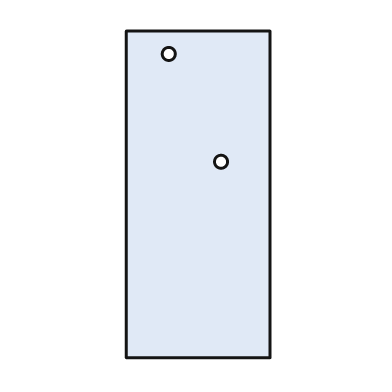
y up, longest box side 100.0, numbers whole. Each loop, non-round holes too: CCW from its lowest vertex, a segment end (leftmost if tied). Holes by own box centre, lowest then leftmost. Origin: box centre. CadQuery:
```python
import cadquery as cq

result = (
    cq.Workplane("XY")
    .moveTo(-22.0, -50.0)
    .lineTo(22.0, -50.0)
    .lineTo(22.0, 50.0)
    .lineTo(-22.0, 50.0)
    .close()
    .moveTo(7.0, 10.0)
    .circle(2.0)
    .moveTo(-9.0, 43.0)
    .circle(2.0)
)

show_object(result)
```